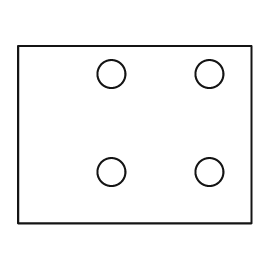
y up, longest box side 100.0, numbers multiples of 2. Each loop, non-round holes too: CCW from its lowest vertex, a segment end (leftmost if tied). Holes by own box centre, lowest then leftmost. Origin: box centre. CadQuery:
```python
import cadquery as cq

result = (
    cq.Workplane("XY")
    .moveTo(-50.0, -38.0)
    .lineTo(50.0, -38.0)
    .lineTo(50.0, 38.0)
    .lineTo(-50.0, 38.0)
    .close()
    .moveTo(-10.0, -16.0)
    .circle(6.0)
    .moveTo(32.0, -16.0)
    .circle(6.0)
    .moveTo(-10.0, 26.0)
    .circle(6.0)
    .moveTo(32.0, 26.0)
    .circle(6.0)
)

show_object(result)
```